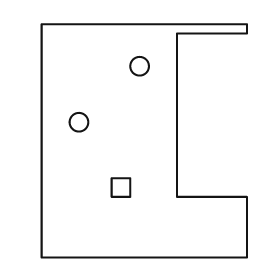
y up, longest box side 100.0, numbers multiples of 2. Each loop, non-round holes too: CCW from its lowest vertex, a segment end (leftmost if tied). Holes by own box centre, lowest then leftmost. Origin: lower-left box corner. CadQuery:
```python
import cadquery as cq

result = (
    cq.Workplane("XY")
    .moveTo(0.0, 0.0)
    .lineTo(88.0, 0.0)
    .lineTo(88.0, 26.0)
    .lineTo(58.0, 26.0)
    .lineTo(58.0, 96.0)
    .lineTo(88.0, 96.0)
    .lineTo(88.0, 100.0)
    .lineTo(0.0, 100.0)
    .close()
    .moveTo(30.0, 26.0)
    .lineTo(38.0, 26.0)
    .lineTo(38.0, 34.0)
    .lineTo(30.0, 34.0)
    .close()
    .moveTo(16.0, 58.0)
    .circle(4.0)
    .moveTo(42.0, 82.0)
    .circle(4.0)
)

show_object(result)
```